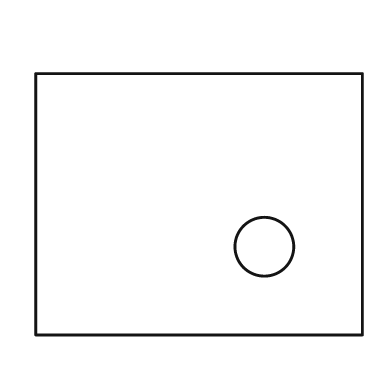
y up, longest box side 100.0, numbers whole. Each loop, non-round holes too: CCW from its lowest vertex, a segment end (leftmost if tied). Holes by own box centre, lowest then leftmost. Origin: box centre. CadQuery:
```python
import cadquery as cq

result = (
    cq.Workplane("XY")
    .moveTo(-50.0, -40.0)
    .lineTo(50.0, -40.0)
    .lineTo(50.0, 40.0)
    .lineTo(-50.0, 40.0)
    .close()
    .moveTo(20.0, -13.0)
    .circle(9.0)
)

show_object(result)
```